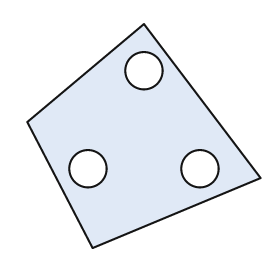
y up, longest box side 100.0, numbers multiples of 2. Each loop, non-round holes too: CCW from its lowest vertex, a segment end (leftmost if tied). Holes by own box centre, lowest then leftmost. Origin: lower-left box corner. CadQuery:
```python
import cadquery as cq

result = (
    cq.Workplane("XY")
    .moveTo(28.0, 0.0)
    .lineTo(100.0, 30.0)
    .lineTo(50.0, 96.0)
    .lineTo(0.0, 54.0)
    .close()
    .moveTo(26.0, 34.0)
    .circle(8.0)
    .moveTo(74.0, 34.0)
    .circle(8.0)
    .moveTo(50.0, 76.0)
    .circle(8.0)
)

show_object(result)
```